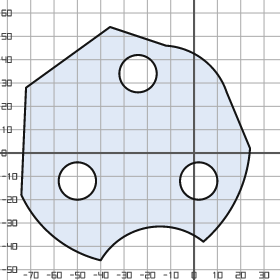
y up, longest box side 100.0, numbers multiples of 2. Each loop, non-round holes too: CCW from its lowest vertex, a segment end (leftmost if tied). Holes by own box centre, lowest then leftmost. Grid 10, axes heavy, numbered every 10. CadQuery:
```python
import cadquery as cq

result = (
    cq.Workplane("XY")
    .moveTo(-40.0, -46.0)
    .threePointArc((-20.0, -32.0), (4.0, -38.0))
    .threePointArc((18.0, -20.0), (24.0, 2.0))
    .lineTo(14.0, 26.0)
    .threePointArc((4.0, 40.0), (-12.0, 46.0))
    .lineTo(-36.0, 54.0)
    .lineTo(-72.0, 28.0)
    .lineTo(-74.0, -18.0)
    .threePointArc((-60.0, -36.0), (-40.0, -46.0))
    .close()
    .moveTo(-50.0, -12.0)
    .circle(8.0)
    .moveTo(2.0, -12.0)
    .circle(8.0)
    .moveTo(-24.0, 34.0)
    .circle(8.0)
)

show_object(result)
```